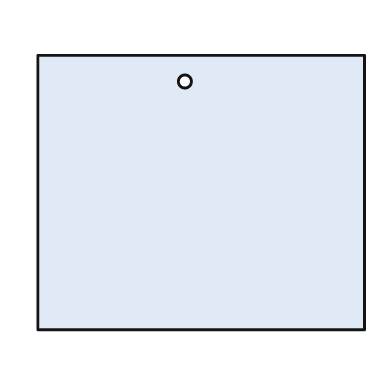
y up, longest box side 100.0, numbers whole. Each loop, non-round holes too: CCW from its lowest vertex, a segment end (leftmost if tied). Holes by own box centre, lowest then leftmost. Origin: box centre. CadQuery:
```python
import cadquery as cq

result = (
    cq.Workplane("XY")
    .moveTo(-50.0, -42.0)
    .lineTo(50.0, -42.0)
    .lineTo(50.0, 42.0)
    .lineTo(-50.0, 42.0)
    .close()
    .moveTo(-5.0, 34.0)
    .circle(2.0)
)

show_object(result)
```